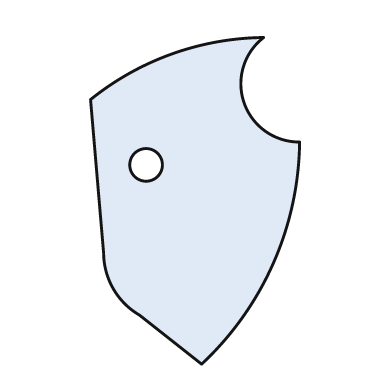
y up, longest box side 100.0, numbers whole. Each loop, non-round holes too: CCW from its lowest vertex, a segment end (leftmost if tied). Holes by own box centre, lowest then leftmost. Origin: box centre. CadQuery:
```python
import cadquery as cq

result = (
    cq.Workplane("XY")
    .moveTo(2.0, -50.0)
    .threePointArc((24.0, -19.0), (32.0, 18.0))
    .threePointArc((15.0, 30.0), (21.0, 50.0))
    .threePointArc((-7.0, 45.0), (-32.0, 31.0))
    .lineTo(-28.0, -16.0)
    .threePointArc((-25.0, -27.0), (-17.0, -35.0))
    .close()
    .moveTo(-15.0, 11.0)
    .circle(5.0)
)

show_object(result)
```